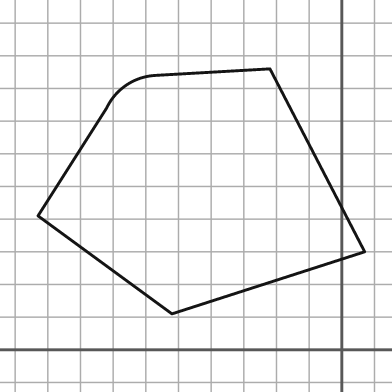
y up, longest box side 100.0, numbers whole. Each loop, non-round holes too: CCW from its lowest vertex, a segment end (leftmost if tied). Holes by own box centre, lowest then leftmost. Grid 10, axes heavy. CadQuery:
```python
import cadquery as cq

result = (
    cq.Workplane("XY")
    .moveTo(-52.0, 11.0)
    .lineTo(7.0, 30.0)
    .lineTo(-22.0, 86.0)
    .lineTo(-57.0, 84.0)
    .threePointArc((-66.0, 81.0), (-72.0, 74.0))
    .lineTo(-93.0, 41.0)
    .close()
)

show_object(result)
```